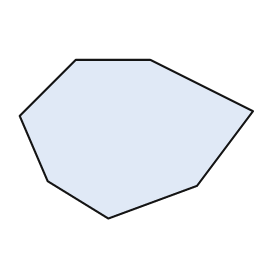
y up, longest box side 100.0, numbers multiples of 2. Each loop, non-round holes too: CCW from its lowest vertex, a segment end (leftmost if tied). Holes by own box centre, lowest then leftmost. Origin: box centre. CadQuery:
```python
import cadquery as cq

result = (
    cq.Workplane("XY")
    .moveTo(-12.0, -34.0)
    .lineTo(26.0, -20.0)
    .lineTo(50.0, 12.0)
    .lineTo(6.0, 34.0)
    .lineTo(-26.0, 34.0)
    .lineTo(-50.0, 10.0)
    .lineTo(-38.0, -18.0)
    .close()
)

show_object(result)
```